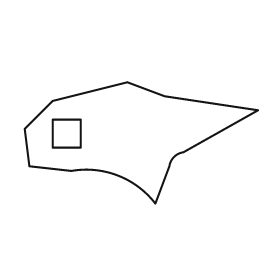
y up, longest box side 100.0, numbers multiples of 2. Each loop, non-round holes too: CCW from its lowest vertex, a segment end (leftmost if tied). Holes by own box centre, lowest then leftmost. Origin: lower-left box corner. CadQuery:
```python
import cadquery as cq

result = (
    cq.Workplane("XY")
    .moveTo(56.0, 0.0)
    .lineTo(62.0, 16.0)
    .threePointArc((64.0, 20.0), (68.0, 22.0))
    .lineTo(100.0, 40.0)
    .lineTo(60.0, 46.0)
    .lineTo(44.0, 52.0)
    .lineTo(12.0, 44.0)
    .lineTo(0.0, 32.0)
    .lineTo(2.0, 16.0)
    .lineTo(20.0, 14.0)
    .threePointArc((40.0, 12.0), (56.0, 0.0))
    .close()
    .moveTo(12.0, 24.0)
    .lineTo(24.0, 24.0)
    .lineTo(24.0, 36.0)
    .lineTo(12.0, 36.0)
    .close()
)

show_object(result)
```